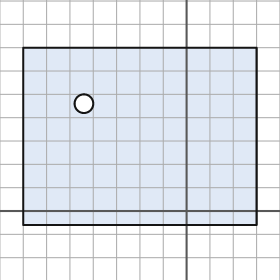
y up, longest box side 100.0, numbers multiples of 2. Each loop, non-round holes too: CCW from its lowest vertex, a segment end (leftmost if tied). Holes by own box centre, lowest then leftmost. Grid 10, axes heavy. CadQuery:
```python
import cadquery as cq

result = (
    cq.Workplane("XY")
    .moveTo(-70.0, -6.0)
    .lineTo(30.0, -6.0)
    .lineTo(30.0, 70.0)
    .lineTo(-70.0, 70.0)
    .close()
    .moveTo(-44.0, 46.0)
    .circle(4.0)
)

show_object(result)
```